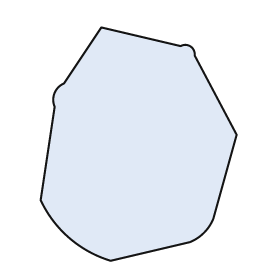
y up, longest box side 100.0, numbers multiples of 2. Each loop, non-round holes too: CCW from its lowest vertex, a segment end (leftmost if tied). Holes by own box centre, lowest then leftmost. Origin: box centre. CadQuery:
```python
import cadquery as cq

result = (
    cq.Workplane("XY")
    .moveTo(-12.0, -50.0)
    .lineTo(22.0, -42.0)
    .threePointArc((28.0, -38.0), (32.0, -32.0))
    .lineTo(42.0, 4.0)
    .lineTo(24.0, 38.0)
    .threePointArc((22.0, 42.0), (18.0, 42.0))
    .lineTo(-16.0, 50.0)
    .lineTo(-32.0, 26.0)
    .threePointArc((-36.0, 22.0), (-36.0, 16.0))
    .lineTo(-42.0, -24.0)
    .threePointArc((-30.0, -40.0), (-12.0, -50.0))
    .close()
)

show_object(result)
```